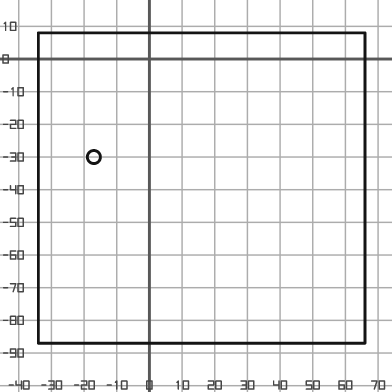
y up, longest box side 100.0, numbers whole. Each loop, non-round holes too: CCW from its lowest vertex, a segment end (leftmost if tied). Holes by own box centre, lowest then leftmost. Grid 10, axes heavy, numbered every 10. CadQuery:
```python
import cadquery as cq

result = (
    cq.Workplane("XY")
    .moveTo(-34.0, -87.0)
    .lineTo(66.0, -87.0)
    .lineTo(66.0, 8.0)
    .lineTo(-34.0, 8.0)
    .close()
    .moveTo(-17.0, -30.0)
    .circle(2.0)
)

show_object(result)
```